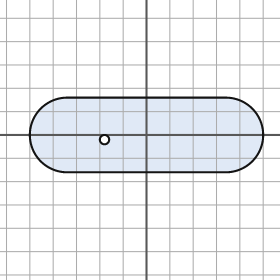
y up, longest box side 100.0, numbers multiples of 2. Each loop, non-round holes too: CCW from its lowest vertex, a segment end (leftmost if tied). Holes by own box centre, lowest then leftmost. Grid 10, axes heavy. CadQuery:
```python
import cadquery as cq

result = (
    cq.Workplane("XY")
    .moveTo(-34.0, -16.0)
    .lineTo(34.0, -16.0)
    .threePointArc((50.0, 0.0), (34.0, 16.0))
    .lineTo(-34.0, 16.0)
    .threePointArc((-50.0, 0.0), (-34.0, -16.0))
    .close()
    .moveTo(-18.0, -2.0)
    .circle(2.0)
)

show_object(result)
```